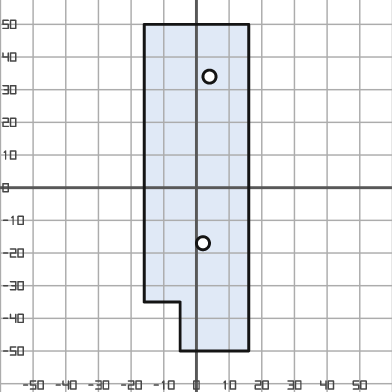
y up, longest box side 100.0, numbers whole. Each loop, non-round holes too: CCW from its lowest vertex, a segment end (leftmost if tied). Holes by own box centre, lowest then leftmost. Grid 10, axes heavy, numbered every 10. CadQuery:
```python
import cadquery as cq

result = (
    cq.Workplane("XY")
    .moveTo(-5.0, -50.0)
    .lineTo(16.0, -50.0)
    .lineTo(16.0, 50.0)
    .lineTo(-16.0, 50.0)
    .lineTo(-16.0, -35.0)
    .lineTo(-5.0, -35.0)
    .close()
    .moveTo(2.0, -17.0)
    .circle(2.0)
    .moveTo(4.0, 34.0)
    .circle(2.0)
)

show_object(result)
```